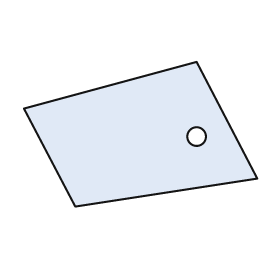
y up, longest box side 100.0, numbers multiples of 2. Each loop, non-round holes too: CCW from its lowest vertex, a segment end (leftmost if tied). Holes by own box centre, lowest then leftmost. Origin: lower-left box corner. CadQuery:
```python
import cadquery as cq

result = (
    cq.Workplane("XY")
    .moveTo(22.0, 0.0)
    .lineTo(100.0, 12.0)
    .lineTo(74.0, 62.0)
    .lineTo(0.0, 42.0)
    .close()
    .moveTo(74.0, 30.0)
    .circle(4.0)
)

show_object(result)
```